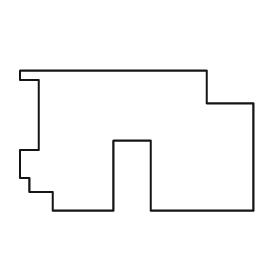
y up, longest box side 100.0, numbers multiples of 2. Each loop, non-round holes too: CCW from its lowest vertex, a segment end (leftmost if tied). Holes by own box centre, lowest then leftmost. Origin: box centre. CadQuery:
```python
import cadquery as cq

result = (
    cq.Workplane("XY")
    .moveTo(-36.0, -30.0)
    .lineTo(-10.0, -30.0)
    .lineTo(-10.0, 0.0)
    .lineTo(6.0, 0.0)
    .lineTo(6.0, -30.0)
    .lineTo(50.0, -30.0)
    .lineTo(50.0, 16.0)
    .lineTo(30.0, 16.0)
    .lineTo(30.0, 30.0)
    .lineTo(-50.0, 30.0)
    .lineTo(-50.0, 26.0)
    .lineTo(-42.0, 26.0)
    .lineTo(-42.0, -4.0)
    .lineTo(-50.0, -4.0)
    .lineTo(-50.0, -16.0)
    .lineTo(-46.0, -16.0)
    .lineTo(-46.0, -22.0)
    .lineTo(-36.0, -22.0)
    .close()
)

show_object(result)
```